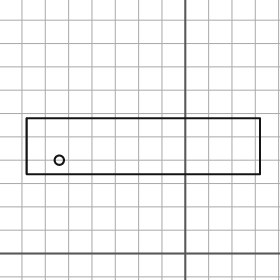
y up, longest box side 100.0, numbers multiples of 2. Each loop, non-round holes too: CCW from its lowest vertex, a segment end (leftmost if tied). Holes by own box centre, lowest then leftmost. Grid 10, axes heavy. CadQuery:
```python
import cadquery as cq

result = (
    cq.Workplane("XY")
    .moveTo(-68.0, 34.0)
    .lineTo(32.0, 34.0)
    .lineTo(32.0, 58.0)
    .lineTo(-68.0, 58.0)
    .close()
    .moveTo(-54.0, 40.0)
    .circle(2.0)
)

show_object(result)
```